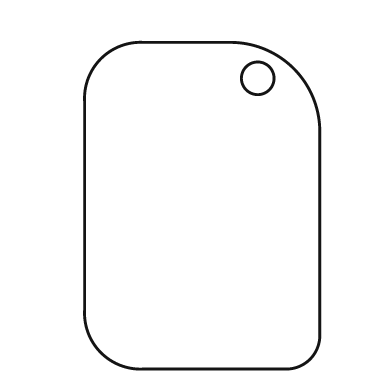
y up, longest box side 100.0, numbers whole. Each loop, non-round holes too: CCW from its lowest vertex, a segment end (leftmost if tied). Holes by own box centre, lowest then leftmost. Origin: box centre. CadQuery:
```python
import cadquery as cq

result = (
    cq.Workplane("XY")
    .moveTo(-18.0, -50.0)
    .lineTo(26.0, -50.0)
    .threePointArc((33.0, -47.0), (36.0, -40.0))
    .lineTo(36.0, 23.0)
    .threePointArc((28.0, 42.0), (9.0, 50.0))
    .lineTo(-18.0, 50.0)
    .threePointArc((-31.0, 45.0), (-36.0, 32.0))
    .lineTo(-36.0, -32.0)
    .threePointArc((-31.0, -45.0), (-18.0, -50.0))
    .close()
    .moveTo(17.0, 39.0)
    .circle(5.0)
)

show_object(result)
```